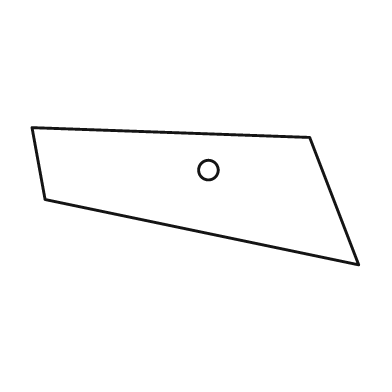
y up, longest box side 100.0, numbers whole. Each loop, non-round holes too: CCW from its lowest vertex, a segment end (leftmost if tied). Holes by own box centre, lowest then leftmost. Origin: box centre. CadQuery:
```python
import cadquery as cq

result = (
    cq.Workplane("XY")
    .moveTo(50.0, -21.0)
    .lineTo(35.0, 18.0)
    .lineTo(-50.0, 21.0)
    .lineTo(-46.0, -1.0)
    .close()
    .moveTo(4.0, 8.0)
    .circle(3.0)
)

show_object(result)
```